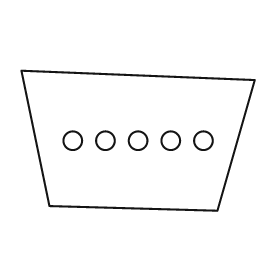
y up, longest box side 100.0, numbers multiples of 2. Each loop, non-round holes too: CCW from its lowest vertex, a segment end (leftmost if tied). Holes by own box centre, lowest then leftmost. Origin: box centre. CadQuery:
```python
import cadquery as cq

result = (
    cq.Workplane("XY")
    .moveTo(34.0, -30.0)
    .lineTo(50.0, 26.0)
    .lineTo(-50.0, 30.0)
    .lineTo(-38.0, -28.0)
    .close()
    .moveTo(-28.0, 0.0)
    .circle(4.0)
    .moveTo(-14.0, 0.0)
    .circle(4.0)
    .moveTo(0.0, 0.0)
    .circle(4.0)
    .moveTo(14.0, 0.0)
    .circle(4.0)
    .moveTo(28.0, 0.0)
    .circle(4.0)
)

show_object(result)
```